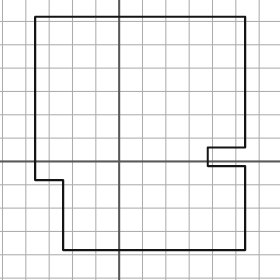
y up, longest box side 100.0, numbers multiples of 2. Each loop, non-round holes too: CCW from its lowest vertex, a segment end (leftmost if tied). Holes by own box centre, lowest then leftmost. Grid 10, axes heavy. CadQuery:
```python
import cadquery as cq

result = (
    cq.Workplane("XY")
    .moveTo(-24.0, -38.0)
    .lineTo(54.0, -38.0)
    .lineTo(54.0, -2.0)
    .lineTo(38.0, -2.0)
    .lineTo(38.0, 6.0)
    .lineTo(54.0, 6.0)
    .lineTo(54.0, 62.0)
    .lineTo(-36.0, 62.0)
    .lineTo(-36.0, -8.0)
    .lineTo(-24.0, -8.0)
    .close()
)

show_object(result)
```